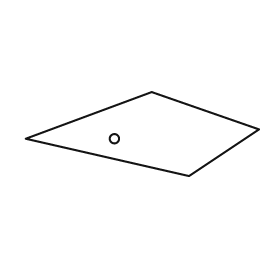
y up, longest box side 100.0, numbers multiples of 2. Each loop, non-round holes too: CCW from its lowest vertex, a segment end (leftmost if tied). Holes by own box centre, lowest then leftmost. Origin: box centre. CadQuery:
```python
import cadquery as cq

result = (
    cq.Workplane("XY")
    .moveTo(20.0, -18.0)
    .lineTo(50.0, 2.0)
    .lineTo(4.0, 18.0)
    .lineTo(-50.0, -2.0)
    .close()
    .moveTo(-12.0, -2.0)
    .circle(2.0)
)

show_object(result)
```